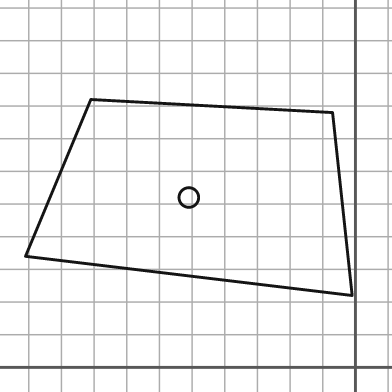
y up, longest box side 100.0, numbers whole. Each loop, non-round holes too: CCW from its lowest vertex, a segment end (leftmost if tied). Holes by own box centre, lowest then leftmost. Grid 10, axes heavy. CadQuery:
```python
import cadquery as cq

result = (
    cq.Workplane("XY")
    .moveTo(-1.0, 22.0)
    .lineTo(-7.0, 78.0)
    .lineTo(-81.0, 82.0)
    .lineTo(-101.0, 34.0)
    .close()
    .moveTo(-51.0, 52.0)
    .circle(3.0)
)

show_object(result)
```